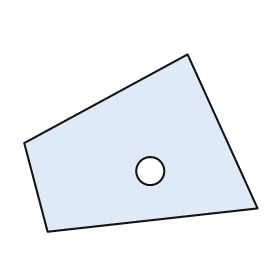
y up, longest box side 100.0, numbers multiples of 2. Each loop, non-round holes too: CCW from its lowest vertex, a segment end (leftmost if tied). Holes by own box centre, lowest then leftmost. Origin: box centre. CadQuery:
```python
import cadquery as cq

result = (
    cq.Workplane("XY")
    .moveTo(-40.0, -38.0)
    .lineTo(50.0, -28.0)
    .lineTo(20.0, 38.0)
    .lineTo(-50.0, 0.0)
    .close()
    .moveTo(4.0, -12.0)
    .circle(6.0)
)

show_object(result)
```